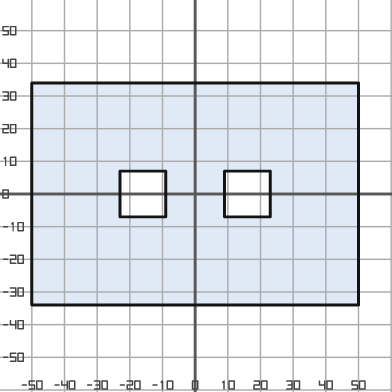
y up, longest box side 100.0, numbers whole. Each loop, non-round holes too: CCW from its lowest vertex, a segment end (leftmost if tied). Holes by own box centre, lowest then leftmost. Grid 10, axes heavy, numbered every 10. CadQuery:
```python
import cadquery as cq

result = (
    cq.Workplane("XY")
    .moveTo(-50.0, -34.0)
    .lineTo(50.0, -34.0)
    .lineTo(50.0, 34.0)
    .lineTo(-50.0, 34.0)
    .close()
    .moveTo(-23.0, -7.0)
    .lineTo(-9.0, -7.0)
    .lineTo(-9.0, 7.0)
    .lineTo(-23.0, 7.0)
    .close()
    .moveTo(9.0, -7.0)
    .lineTo(23.0, -7.0)
    .lineTo(23.0, 7.0)
    .lineTo(9.0, 7.0)
    .close()
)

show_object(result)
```